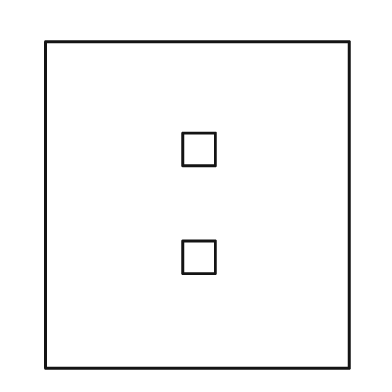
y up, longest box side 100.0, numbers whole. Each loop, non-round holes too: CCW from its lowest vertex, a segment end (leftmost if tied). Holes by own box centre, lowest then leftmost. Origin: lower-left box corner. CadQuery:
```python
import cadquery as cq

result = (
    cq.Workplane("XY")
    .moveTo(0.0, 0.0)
    .lineTo(93.0, 0.0)
    .lineTo(93.0, 100.0)
    .lineTo(0.0, 100.0)
    .close()
    .moveTo(42.0, 29.0)
    .lineTo(52.0, 29.0)
    .lineTo(52.0, 39.0)
    .lineTo(42.0, 39.0)
    .close()
    .moveTo(42.0, 62.0)
    .lineTo(52.0, 62.0)
    .lineTo(52.0, 72.0)
    .lineTo(42.0, 72.0)
    .close()
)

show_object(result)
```